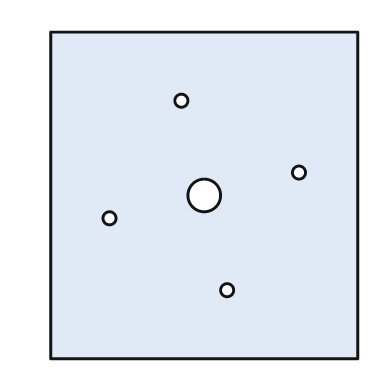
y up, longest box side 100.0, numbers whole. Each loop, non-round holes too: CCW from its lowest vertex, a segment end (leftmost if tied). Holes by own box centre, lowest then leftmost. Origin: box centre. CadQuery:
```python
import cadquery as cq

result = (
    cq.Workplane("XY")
    .moveTo(-47.0, -50.0)
    .lineTo(47.0, -50.0)
    .lineTo(47.0, 50.0)
    .lineTo(-47.0, 50.0)
    .close()
    .moveTo(7.0, -29.0)
    .circle(2.0)
    .moveTo(-29.0, -7.0)
    .circle(2.0)
    .moveTo(0.0, 0.0)
    .circle(5.0)
    .moveTo(29.0, 7.0)
    .circle(2.0)
    .moveTo(-7.0, 29.0)
    .circle(2.0)
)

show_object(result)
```